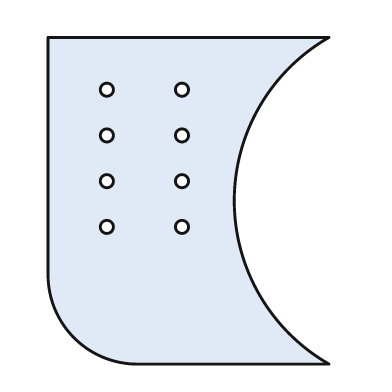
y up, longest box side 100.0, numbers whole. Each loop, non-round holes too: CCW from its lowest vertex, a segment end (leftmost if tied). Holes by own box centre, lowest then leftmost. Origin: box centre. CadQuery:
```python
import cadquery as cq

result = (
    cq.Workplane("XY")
    .moveTo(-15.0, -50.0)
    .lineTo(43.0, -50.0)
    .threePointArc((14.0, 0.0), (43.0, 50.0))
    .lineTo(-43.0, 50.0)
    .lineTo(-43.0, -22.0)
    .threePointArc((-35.0, -42.0), (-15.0, -50.0))
    .close()
    .moveTo(-25.0, -8.0)
    .circle(2.0)
    .moveTo(-2.0, -8.0)
    .circle(2.0)
    .moveTo(-25.0, 6.0)
    .circle(2.0)
    .moveTo(-2.0, 6.0)
    .circle(2.0)
    .moveTo(-25.0, 20.0)
    .circle(2.0)
    .moveTo(-2.0, 20.0)
    .circle(2.0)
    .moveTo(-25.0, 34.0)
    .circle(2.0)
    .moveTo(-2.0, 34.0)
    .circle(2.0)
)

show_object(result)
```